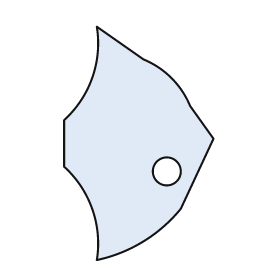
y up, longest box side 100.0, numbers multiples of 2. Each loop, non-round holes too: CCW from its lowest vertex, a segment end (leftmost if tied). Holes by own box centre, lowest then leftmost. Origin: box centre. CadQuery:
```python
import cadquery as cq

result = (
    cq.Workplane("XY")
    .moveTo(-18.0, -50.0)
    .threePointArc((2.0, -42.0), (18.0, -28.0))
    .lineTo(32.0, 2.0)
    .lineTo(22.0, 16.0)
    .threePointArc((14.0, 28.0), (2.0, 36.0))
    .lineTo(-18.0, 50.0)
    .threePointArc((-20.0, 28.0), (-32.0, 10.0))
    .lineTo(-32.0, -10.0)
    .threePointArc((-20.0, -28.0), (-18.0, -50.0))
    .close()
    .moveTo(12.0, -12.0)
    .circle(6.0)
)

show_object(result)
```